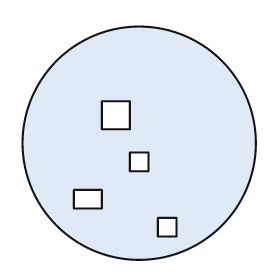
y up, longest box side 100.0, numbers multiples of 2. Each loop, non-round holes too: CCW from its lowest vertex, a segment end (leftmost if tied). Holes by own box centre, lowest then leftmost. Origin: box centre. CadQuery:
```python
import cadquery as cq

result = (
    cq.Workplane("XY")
    .moveTo(0.0, 0.0)
    .circle(50.0)
    .moveTo(8.0, -40.0)
    .lineTo(16.0, -40.0)
    .lineTo(16.0, -32.0)
    .lineTo(8.0, -32.0)
    .close()
    .moveTo(-28.0, -28.0)
    .lineTo(-16.0, -28.0)
    .lineTo(-16.0, -20.0)
    .lineTo(-28.0, -20.0)
    .close()
    .moveTo(-4.0, -12.0)
    .lineTo(4.0, -12.0)
    .lineTo(4.0, -4.0)
    .lineTo(-4.0, -4.0)
    .close()
    .moveTo(-16.0, 6.0)
    .lineTo(-4.0, 6.0)
    .lineTo(-4.0, 18.0)
    .lineTo(-16.0, 18.0)
    .close()
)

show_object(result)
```